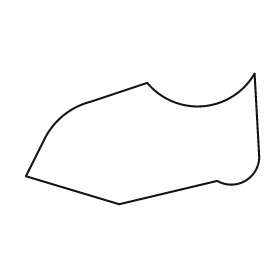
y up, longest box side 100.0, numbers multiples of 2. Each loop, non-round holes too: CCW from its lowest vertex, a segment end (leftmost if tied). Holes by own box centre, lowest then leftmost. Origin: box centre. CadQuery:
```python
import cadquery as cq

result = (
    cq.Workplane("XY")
    .moveTo(-10.0, -28.0)
    .lineTo(32.0, -18.0)
    .threePointArc((44.0, -18.0), (50.0, -8.0))
    .lineTo(48.0, 28.0)
    .threePointArc((26.0, 14.0), (2.0, 24.0))
    .lineTo(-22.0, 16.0)
    .threePointArc((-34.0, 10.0), (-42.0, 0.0))
    .lineTo(-50.0, -16.0)
    .close()
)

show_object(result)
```